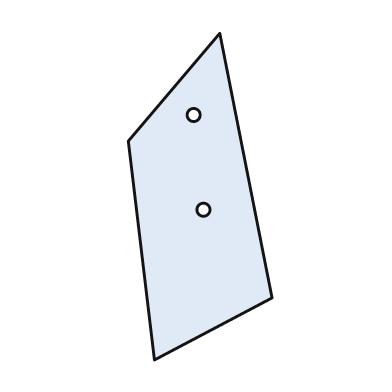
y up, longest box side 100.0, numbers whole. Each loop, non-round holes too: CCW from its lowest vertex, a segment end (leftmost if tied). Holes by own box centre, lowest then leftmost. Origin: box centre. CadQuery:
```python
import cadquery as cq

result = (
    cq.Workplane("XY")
    .moveTo(-14.0, -50.0)
    .lineTo(22.0, -31.0)
    .lineTo(6.0, 50.0)
    .lineTo(-22.0, 17.0)
    .close()
    .moveTo(1.0, -4.0)
    .circle(2.0)
    .moveTo(-2.0, 25.0)
    .circle(2.0)
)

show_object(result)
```